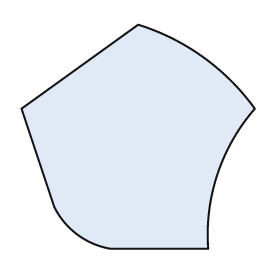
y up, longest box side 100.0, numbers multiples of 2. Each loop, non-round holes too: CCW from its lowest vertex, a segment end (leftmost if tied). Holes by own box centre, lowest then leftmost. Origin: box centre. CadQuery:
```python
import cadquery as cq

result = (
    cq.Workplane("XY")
    .moveTo(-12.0, -48.0)
    .lineTo(30.0, -48.0)
    .threePointArc((34.0, -16.0), (50.0, 12.0))
    .threePointArc((28.0, 34.0), (0.0, 48.0))
    .lineTo(-50.0, 12.0)
    .lineTo(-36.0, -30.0)
    .threePointArc((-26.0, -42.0), (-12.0, -48.0))
    .close()
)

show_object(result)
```